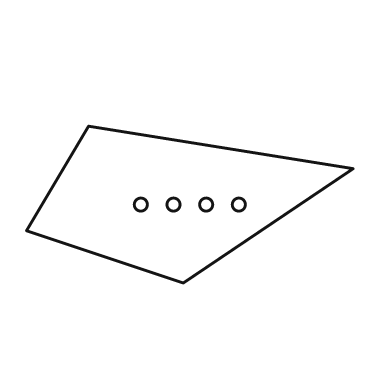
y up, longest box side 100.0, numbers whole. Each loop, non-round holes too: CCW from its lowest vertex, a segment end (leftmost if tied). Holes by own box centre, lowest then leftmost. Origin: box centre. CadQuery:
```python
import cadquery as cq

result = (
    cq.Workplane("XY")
    .moveTo(-2.0, -24.0)
    .lineTo(50.0, 11.0)
    .lineTo(-31.0, 24.0)
    .lineTo(-50.0, -8.0)
    .close()
    .moveTo(-15.0, 0.0)
    .circle(2.0)
    .moveTo(-5.0, 0.0)
    .circle(2.0)
    .moveTo(5.0, 0.0)
    .circle(2.0)
    .moveTo(15.0, 0.0)
    .circle(2.0)
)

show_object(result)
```